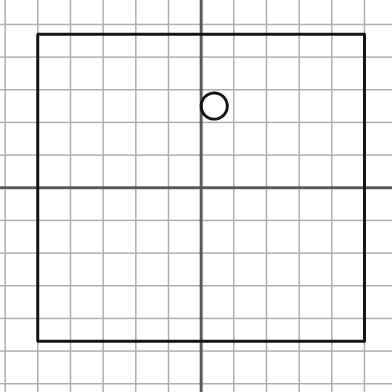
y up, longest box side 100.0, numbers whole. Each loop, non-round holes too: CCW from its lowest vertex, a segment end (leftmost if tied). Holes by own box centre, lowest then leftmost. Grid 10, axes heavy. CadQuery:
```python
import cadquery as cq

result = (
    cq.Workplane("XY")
    .moveTo(-50.0, -47.0)
    .lineTo(50.0, -47.0)
    .lineTo(50.0, 47.0)
    .lineTo(-50.0, 47.0)
    .close()
    .moveTo(4.0, 25.0)
    .circle(4.0)
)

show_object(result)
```